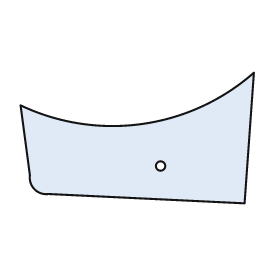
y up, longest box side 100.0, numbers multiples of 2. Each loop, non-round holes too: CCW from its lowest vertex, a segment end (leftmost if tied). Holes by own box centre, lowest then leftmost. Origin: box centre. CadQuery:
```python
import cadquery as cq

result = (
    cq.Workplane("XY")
    .moveTo(46.0, -28.0)
    .lineTo(50.0, 28.0)
    .threePointArc((2.0, 6.0), (-50.0, 14.0))
    .lineTo(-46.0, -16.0)
    .threePointArc((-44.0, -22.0), (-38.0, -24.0))
    .close()
    .moveTo(10.0, -12.0)
    .circle(2.0)
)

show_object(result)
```